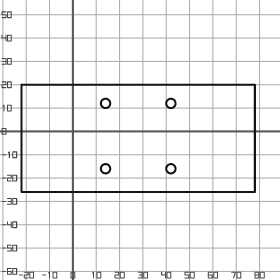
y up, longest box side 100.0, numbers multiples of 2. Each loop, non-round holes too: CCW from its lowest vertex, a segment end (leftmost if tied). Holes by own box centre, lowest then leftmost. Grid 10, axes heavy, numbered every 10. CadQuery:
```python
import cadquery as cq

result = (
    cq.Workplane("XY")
    .moveTo(-22.0, -26.0)
    .lineTo(78.0, -26.0)
    .lineTo(78.0, 20.0)
    .lineTo(-22.0, 20.0)
    .close()
    .moveTo(14.0, -16.0)
    .circle(2.0)
    .moveTo(42.0, -16.0)
    .circle(2.0)
    .moveTo(14.0, 12.0)
    .circle(2.0)
    .moveTo(42.0, 12.0)
    .circle(2.0)
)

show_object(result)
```